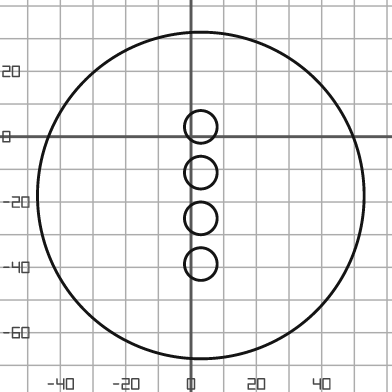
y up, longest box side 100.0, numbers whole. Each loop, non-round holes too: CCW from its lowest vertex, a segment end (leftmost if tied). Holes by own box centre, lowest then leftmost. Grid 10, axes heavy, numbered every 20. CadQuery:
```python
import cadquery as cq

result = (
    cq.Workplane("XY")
    .moveTo(3.0, -18.0)
    .circle(50.0)
    .moveTo(3.0, -39.0)
    .circle(5.0)
    .moveTo(3.0, -25.0)
    .circle(5.0)
    .moveTo(3.0, -11.0)
    .circle(5.0)
    .moveTo(3.0, 3.0)
    .circle(5.0)
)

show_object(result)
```